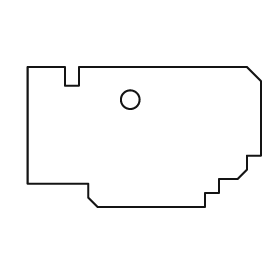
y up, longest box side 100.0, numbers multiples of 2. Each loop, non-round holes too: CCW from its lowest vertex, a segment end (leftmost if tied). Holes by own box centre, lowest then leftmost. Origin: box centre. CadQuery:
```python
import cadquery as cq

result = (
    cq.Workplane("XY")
    .moveTo(-20.0, -30.0)
    .lineTo(26.0, -30.0)
    .lineTo(26.0, -24.0)
    .lineTo(32.0, -24.0)
    .lineTo(32.0, -18.0)
    .lineTo(40.0, -18.0)
    .lineTo(44.0, -14.0)
    .lineTo(44.0, -8.0)
    .lineTo(50.0, -8.0)
    .lineTo(50.0, 24.0)
    .lineTo(44.0, 30.0)
    .lineTo(-28.0, 30.0)
    .lineTo(-28.0, 22.0)
    .lineTo(-34.0, 22.0)
    .lineTo(-34.0, 30.0)
    .lineTo(-50.0, 30.0)
    .lineTo(-50.0, -20.0)
    .lineTo(-24.0, -20.0)
    .lineTo(-24.0, -26.0)
    .close()
    .moveTo(-6.0, 16.0)
    .circle(4.0)
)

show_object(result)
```